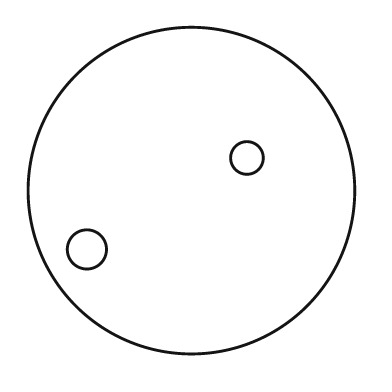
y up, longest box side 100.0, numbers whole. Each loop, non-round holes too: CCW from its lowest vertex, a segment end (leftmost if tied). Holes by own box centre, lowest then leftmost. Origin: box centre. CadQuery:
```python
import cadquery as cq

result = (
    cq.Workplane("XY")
    .moveTo(0.0, 0.0)
    .circle(50.0)
    .moveTo(-32.0, -18.0)
    .circle(6.0)
    .moveTo(17.0, 10.0)
    .circle(5.0)
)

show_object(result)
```